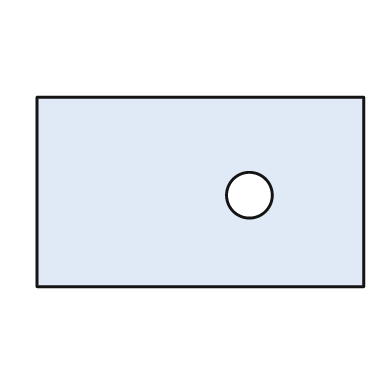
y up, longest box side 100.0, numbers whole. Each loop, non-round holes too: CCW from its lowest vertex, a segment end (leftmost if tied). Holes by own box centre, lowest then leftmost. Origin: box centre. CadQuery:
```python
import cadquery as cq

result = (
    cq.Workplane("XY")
    .moveTo(-50.0, -29.0)
    .lineTo(50.0, -29.0)
    .lineTo(50.0, 29.0)
    .lineTo(-50.0, 29.0)
    .close()
    .moveTo(15.0, -1.0)
    .circle(7.0)
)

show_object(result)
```